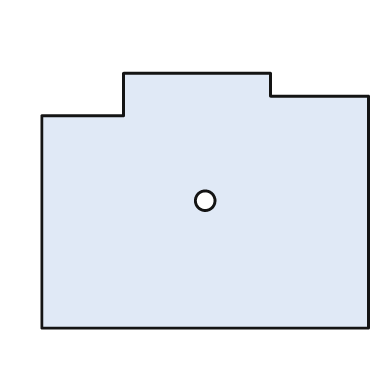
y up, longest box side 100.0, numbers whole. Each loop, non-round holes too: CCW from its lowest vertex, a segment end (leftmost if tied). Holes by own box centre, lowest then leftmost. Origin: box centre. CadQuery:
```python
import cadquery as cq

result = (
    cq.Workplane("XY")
    .moveTo(-50.0, -39.0)
    .lineTo(50.0, -39.0)
    .lineTo(50.0, 32.0)
    .lineTo(20.0, 32.0)
    .lineTo(20.0, 39.0)
    .lineTo(-25.0, 39.0)
    .lineTo(-25.0, 26.0)
    .lineTo(-50.0, 26.0)
    .close()
    .moveTo(0.0, 0.0)
    .circle(3.0)
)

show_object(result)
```